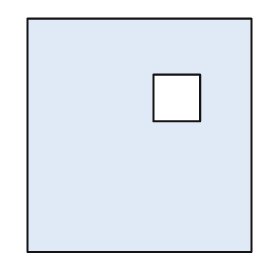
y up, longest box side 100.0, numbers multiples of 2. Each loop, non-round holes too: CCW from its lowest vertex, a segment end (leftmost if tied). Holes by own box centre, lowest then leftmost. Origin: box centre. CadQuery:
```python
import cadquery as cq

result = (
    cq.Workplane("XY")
    .moveTo(-48.0, -50.0)
    .lineTo(48.0, -50.0)
    .lineTo(48.0, 50.0)
    .lineTo(-48.0, 50.0)
    .close()
    .moveTo(6.0, 6.0)
    .lineTo(26.0, 6.0)
    .lineTo(26.0, 26.0)
    .lineTo(6.0, 26.0)
    .close()
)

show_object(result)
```